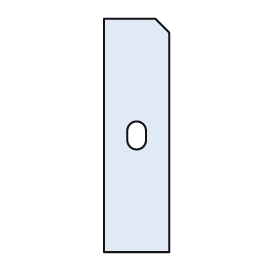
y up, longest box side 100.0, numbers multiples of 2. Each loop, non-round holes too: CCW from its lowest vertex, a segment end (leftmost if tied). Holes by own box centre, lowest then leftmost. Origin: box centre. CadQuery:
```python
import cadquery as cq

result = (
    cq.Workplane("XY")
    .moveTo(-14.0, -50.0)
    .lineTo(14.0, -50.0)
    .lineTo(14.0, 44.0)
    .lineTo(8.0, 50.0)
    .lineTo(-14.0, 50.0)
    .close()
    .moveTo(-4.0, -2.0)
    .threePointArc((0.0, -6.0), (4.0, -2.0))
    .lineTo(4.0, 2.0)
    .threePointArc((0.0, 6.0), (-4.0, 2.0))
    .close()
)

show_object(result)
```